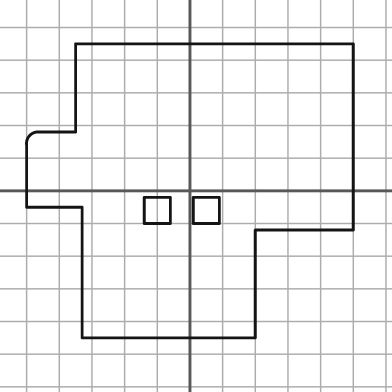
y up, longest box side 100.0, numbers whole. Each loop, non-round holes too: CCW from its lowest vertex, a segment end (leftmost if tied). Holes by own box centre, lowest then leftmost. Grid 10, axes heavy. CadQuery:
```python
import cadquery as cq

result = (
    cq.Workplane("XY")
    .moveTo(-33.0, -45.0)
    .lineTo(20.0, -45.0)
    .lineTo(20.0, -12.0)
    .lineTo(50.0, -12.0)
    .lineTo(50.0, 45.0)
    .lineTo(-35.0, 45.0)
    .lineTo(-35.0, 18.0)
    .lineTo(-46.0, 18.0)
    .threePointArc((-49.0, 17.0), (-50.0, 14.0))
    .lineTo(-50.0, -5.0)
    .lineTo(-33.0, -5.0)
    .close()
    .moveTo(-14.0, -10.0)
    .lineTo(-6.0, -10.0)
    .lineTo(-6.0, -2.0)
    .lineTo(-14.0, -2.0)
    .close()
    .moveTo(1.0, -10.0)
    .lineTo(9.0, -10.0)
    .lineTo(9.0, -2.0)
    .lineTo(1.0, -2.0)
    .close()
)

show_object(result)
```